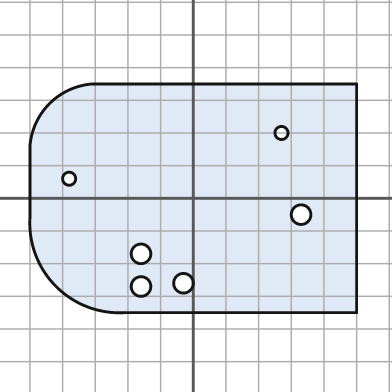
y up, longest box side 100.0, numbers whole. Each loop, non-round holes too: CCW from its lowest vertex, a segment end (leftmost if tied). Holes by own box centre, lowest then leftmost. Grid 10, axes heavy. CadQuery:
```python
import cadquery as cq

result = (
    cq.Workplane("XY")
    .moveTo(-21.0, -35.0)
    .lineTo(50.0, -35.0)
    .lineTo(50.0, 35.0)
    .lineTo(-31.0, 35.0)
    .threePointArc((-44.0, 29.0), (-50.0, 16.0))
    .lineTo(-50.0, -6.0)
    .threePointArc((-42.0, -27.0), (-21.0, -35.0))
    .close()
    .moveTo(-16.0, -27.0)
    .circle(3.0)
    .moveTo(-3.0, -26.0)
    .circle(3.0)
    .moveTo(-16.0, -17.0)
    .circle(3.0)
    .moveTo(33.0, -5.0)
    .circle(3.0)
    .moveTo(-38.0, 6.0)
    .circle(2.0)
    .moveTo(27.0, 20.0)
    .circle(2.0)
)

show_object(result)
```